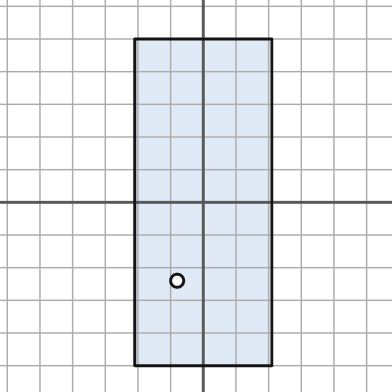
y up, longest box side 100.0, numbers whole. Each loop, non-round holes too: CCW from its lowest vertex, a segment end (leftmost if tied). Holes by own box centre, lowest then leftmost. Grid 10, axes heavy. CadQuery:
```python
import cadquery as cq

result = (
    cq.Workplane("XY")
    .moveTo(-21.0, -50.0)
    .lineTo(21.0, -50.0)
    .lineTo(21.0, 50.0)
    .lineTo(-21.0, 50.0)
    .close()
    .moveTo(-8.0, -24.0)
    .circle(2.0)
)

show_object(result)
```